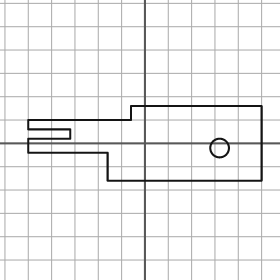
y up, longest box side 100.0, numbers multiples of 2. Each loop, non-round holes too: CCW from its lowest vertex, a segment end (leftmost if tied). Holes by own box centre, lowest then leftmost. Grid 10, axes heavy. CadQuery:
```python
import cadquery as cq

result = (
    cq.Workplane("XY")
    .moveTo(-16.0, -16.0)
    .lineTo(50.0, -16.0)
    .lineTo(50.0, 16.0)
    .lineTo(-6.0, 16.0)
    .lineTo(-6.0, 10.0)
    .lineTo(-50.0, 10.0)
    .lineTo(-50.0, 6.0)
    .lineTo(-32.0, 6.0)
    .lineTo(-32.0, 2.0)
    .lineTo(-50.0, 2.0)
    .lineTo(-50.0, -4.0)
    .lineTo(-16.0, -4.0)
    .close()
    .moveTo(32.0, -2.0)
    .circle(4.0)
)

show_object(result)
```